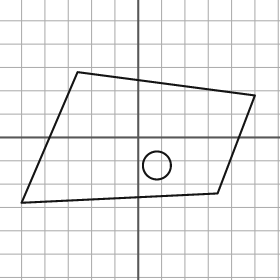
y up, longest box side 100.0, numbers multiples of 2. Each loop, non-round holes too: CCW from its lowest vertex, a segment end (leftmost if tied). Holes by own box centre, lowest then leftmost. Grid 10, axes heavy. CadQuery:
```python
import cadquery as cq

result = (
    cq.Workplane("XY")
    .moveTo(-50.0, -28.0)
    .lineTo(34.0, -24.0)
    .lineTo(50.0, 18.0)
    .lineTo(-26.0, 28.0)
    .close()
    .moveTo(8.0, -12.0)
    .circle(6.0)
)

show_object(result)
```